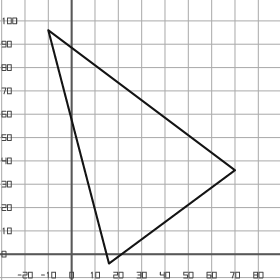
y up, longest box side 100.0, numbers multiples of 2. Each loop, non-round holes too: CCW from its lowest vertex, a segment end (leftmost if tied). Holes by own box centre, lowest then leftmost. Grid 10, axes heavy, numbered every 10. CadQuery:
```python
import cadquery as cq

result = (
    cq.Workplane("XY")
    .moveTo(16.0, -4.0)
    .lineTo(70.0, 36.0)
    .lineTo(-10.0, 96.0)
    .close()
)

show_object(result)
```